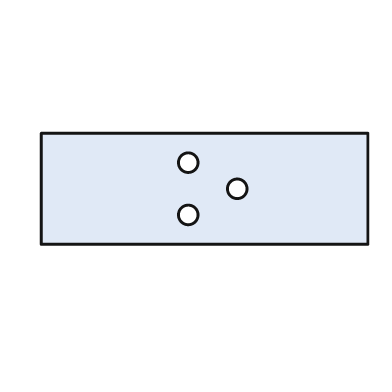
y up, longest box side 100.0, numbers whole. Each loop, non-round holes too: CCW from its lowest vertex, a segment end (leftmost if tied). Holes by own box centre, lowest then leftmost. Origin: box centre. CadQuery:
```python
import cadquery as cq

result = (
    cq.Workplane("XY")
    .moveTo(-50.0, -17.0)
    .lineTo(50.0, -17.0)
    .lineTo(50.0, 17.0)
    .lineTo(-50.0, 17.0)
    .close()
    .moveTo(-5.0, -8.0)
    .circle(3.0)
    .moveTo(10.0, 0.0)
    .circle(3.0)
    .moveTo(-5.0, 8.0)
    .circle(3.0)
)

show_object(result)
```